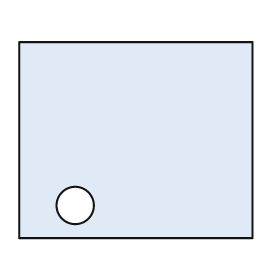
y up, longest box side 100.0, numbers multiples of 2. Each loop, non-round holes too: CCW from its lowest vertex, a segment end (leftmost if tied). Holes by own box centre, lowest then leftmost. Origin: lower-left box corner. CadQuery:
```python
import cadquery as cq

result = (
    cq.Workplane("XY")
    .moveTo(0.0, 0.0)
    .lineTo(100.0, 0.0)
    .lineTo(100.0, 84.0)
    .lineTo(0.0, 84.0)
    .close()
    .moveTo(24.0, 14.0)
    .circle(8.0)
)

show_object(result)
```